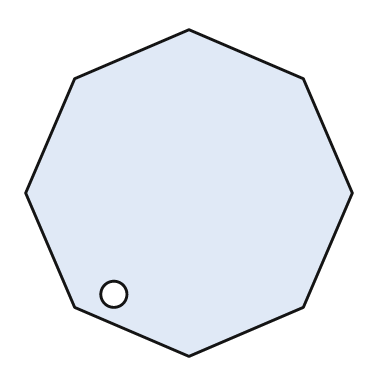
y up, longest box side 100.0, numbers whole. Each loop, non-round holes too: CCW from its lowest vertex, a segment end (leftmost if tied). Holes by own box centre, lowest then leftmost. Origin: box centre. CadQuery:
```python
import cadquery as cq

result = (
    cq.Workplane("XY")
    .moveTo(0.0, -50.0)
    .lineTo(35.0, -35.0)
    .lineTo(50.0, 0.0)
    .lineTo(35.0, 35.0)
    .lineTo(0.0, 50.0)
    .lineTo(-35.0, 35.0)
    .lineTo(-50.0, 0.0)
    .lineTo(-35.0, -35.0)
    .close()
    .moveTo(-23.0, -31.0)
    .circle(4.0)
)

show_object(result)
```